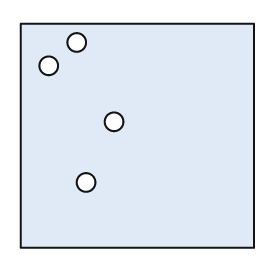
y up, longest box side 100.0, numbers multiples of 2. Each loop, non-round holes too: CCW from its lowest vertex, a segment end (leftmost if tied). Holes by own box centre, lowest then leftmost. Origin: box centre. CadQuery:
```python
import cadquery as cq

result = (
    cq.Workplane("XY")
    .moveTo(-50.0, -48.0)
    .lineTo(50.0, -48.0)
    .lineTo(50.0, 48.0)
    .lineTo(-50.0, 48.0)
    .close()
    .moveTo(-22.0, -20.0)
    .circle(4.0)
    .moveTo(-10.0, 6.0)
    .circle(4.0)
    .moveTo(-38.0, 30.0)
    .circle(4.0)
    .moveTo(-26.0, 40.0)
    .circle(4.0)
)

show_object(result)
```